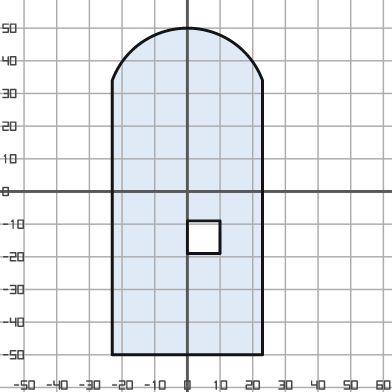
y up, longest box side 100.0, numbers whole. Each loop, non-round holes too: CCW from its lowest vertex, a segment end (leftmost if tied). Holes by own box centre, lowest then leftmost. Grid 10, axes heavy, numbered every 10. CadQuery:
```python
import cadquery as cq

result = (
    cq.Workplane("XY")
    .moveTo(-23.0, -50.0)
    .lineTo(23.0, -50.0)
    .lineTo(23.0, 34.0)
    .threePointArc((0.0, 50.0), (-23.0, 34.0))
    .close()
    .moveTo(0.0, -19.0)
    .lineTo(10.0, -19.0)
    .lineTo(10.0, -9.0)
    .lineTo(0.0, -9.0)
    .close()
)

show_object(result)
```